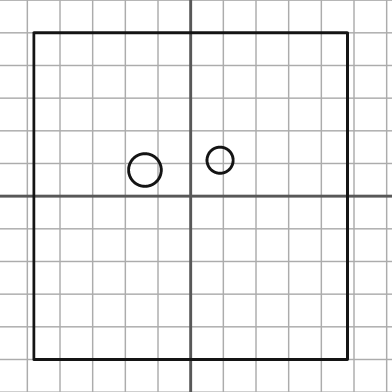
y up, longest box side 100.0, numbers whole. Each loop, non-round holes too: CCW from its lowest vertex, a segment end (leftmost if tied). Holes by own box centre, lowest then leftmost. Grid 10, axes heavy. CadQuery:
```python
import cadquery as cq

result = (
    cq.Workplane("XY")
    .moveTo(-48.0, -50.0)
    .lineTo(48.0, -50.0)
    .lineTo(48.0, 50.0)
    .lineTo(-48.0, 50.0)
    .close()
    .moveTo(-14.0, 8.0)
    .circle(5.0)
    .moveTo(9.0, 11.0)
    .circle(4.0)
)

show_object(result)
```